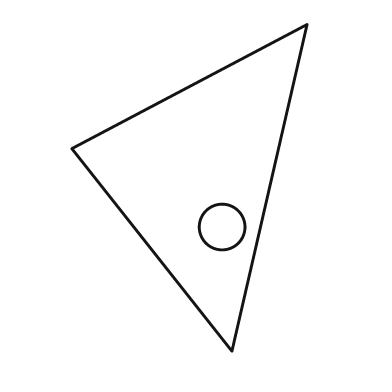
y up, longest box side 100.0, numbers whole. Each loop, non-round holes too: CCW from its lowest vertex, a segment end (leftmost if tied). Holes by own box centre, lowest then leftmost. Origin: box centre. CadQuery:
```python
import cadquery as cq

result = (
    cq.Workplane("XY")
    .moveTo(13.0, -50.0)
    .lineTo(36.0, 50.0)
    .lineTo(-36.0, 12.0)
    .close()
    .moveTo(10.0, -12.0)
    .circle(7.0)
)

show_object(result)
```